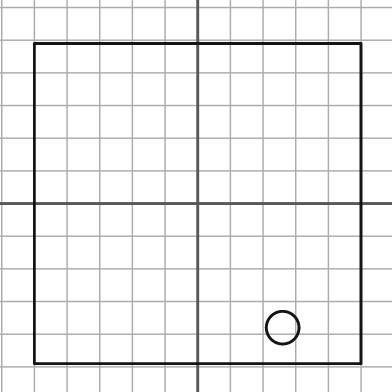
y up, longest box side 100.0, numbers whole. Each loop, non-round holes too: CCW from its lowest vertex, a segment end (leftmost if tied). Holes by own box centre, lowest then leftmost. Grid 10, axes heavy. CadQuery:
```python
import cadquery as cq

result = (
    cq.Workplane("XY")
    .moveTo(-50.0, -49.0)
    .lineTo(50.0, -49.0)
    .lineTo(50.0, 49.0)
    .lineTo(-50.0, 49.0)
    .close()
    .moveTo(26.0, -38.0)
    .circle(5.0)
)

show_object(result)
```